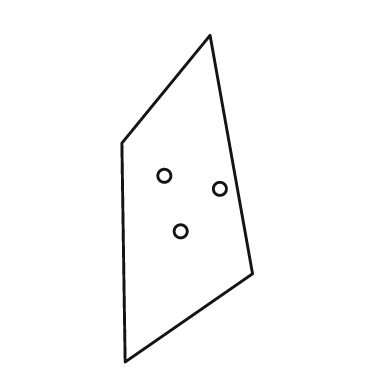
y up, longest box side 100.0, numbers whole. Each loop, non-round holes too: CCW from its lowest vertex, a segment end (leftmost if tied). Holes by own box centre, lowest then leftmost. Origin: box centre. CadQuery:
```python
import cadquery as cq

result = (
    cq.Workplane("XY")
    .moveTo(-19.0, -50.0)
    .lineTo(20.0, -23.0)
    .lineTo(7.0, 50.0)
    .lineTo(-20.0, 17.0)
    .close()
    .moveTo(-2.0, -10.0)
    .circle(2.0)
    .moveTo(10.0, 3.0)
    .circle(2.0)
    .moveTo(-7.0, 7.0)
    .circle(2.0)
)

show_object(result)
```